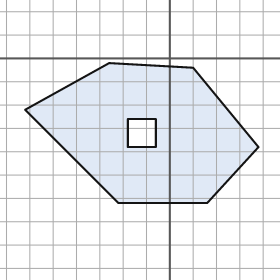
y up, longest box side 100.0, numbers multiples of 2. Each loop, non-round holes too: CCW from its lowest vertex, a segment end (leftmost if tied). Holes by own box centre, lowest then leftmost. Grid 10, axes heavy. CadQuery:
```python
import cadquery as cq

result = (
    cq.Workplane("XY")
    .moveTo(-22.0, -62.0)
    .lineTo(16.0, -62.0)
    .lineTo(38.0, -38.0)
    .lineTo(10.0, -4.0)
    .lineTo(-26.0, -2.0)
    .lineTo(-62.0, -22.0)
    .close()
    .moveTo(-18.0, -38.0)
    .lineTo(-6.0, -38.0)
    .lineTo(-6.0, -26.0)
    .lineTo(-18.0, -26.0)
    .close()
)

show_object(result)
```